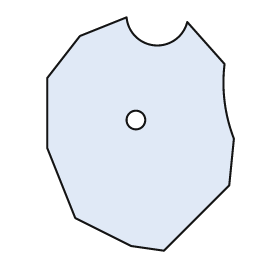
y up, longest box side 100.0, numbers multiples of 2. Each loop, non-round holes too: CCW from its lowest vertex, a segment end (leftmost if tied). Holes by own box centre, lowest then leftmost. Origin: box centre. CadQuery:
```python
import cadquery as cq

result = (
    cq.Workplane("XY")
    .moveTo(10.0, -50.0)
    .lineTo(38.0, -22.0)
    .lineTo(40.0, -2.0)
    .threePointArc((36.0, 14.0), (36.0, 30.0))
    .lineTo(20.0, 48.0)
    .threePointArc((6.0, 38.0), (-6.0, 50.0))
    .lineTo(-26.0, 42.0)
    .lineTo(-40.0, 24.0)
    .lineTo(-40.0, -6.0)
    .lineTo(-28.0, -36.0)
    .lineTo(-4.0, -48.0)
    .close()
    .moveTo(-2.0, 6.0)
    .circle(4.0)
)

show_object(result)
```